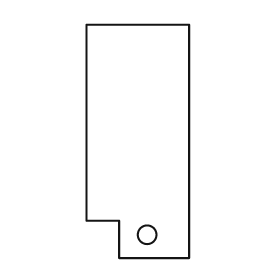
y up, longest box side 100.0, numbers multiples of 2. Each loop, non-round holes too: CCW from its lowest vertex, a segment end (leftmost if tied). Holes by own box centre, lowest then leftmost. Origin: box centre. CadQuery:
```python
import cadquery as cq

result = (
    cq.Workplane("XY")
    .moveTo(-8.0, -50.0)
    .lineTo(22.0, -50.0)
    .lineTo(22.0, 50.0)
    .lineTo(-22.0, 50.0)
    .lineTo(-22.0, -34.0)
    .lineTo(-8.0, -34.0)
    .close()
    .moveTo(4.0, -40.0)
    .circle(4.0)
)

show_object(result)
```